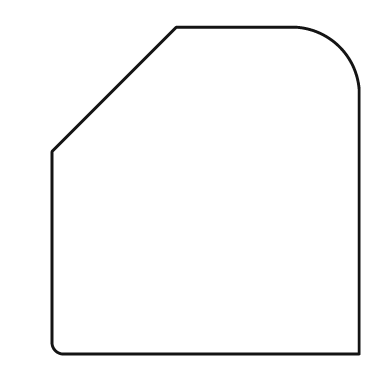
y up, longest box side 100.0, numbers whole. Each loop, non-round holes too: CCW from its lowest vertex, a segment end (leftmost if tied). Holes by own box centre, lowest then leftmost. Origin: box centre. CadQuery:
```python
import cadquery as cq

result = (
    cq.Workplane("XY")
    .moveTo(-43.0, -50.0)
    .lineTo(47.0, -50.0)
    .lineTo(47.0, 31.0)
    .threePointArc((41.0, 44.0), (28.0, 50.0))
    .lineTo(-9.0, 50.0)
    .lineTo(-47.0, 12.0)
    .lineTo(-47.0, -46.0)
    .threePointArc((-46.0, -49.0), (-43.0, -50.0))
    .close()
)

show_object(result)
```